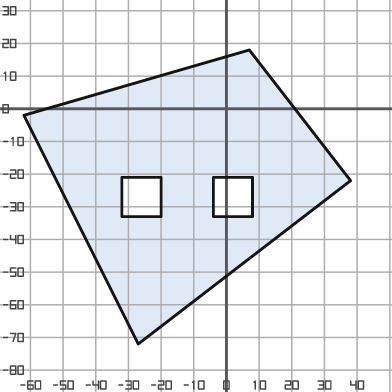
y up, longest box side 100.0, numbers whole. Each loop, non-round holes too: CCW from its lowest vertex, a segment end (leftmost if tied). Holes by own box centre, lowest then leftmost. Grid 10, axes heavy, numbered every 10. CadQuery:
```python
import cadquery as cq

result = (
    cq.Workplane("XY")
    .moveTo(-27.0, -72.0)
    .lineTo(38.0, -22.0)
    .lineTo(7.0, 18.0)
    .lineTo(-62.0, -2.0)
    .close()
    .moveTo(-32.0, -33.0)
    .lineTo(-20.0, -33.0)
    .lineTo(-20.0, -21.0)
    .lineTo(-32.0, -21.0)
    .close()
    .moveTo(-4.0, -33.0)
    .lineTo(8.0, -33.0)
    .lineTo(8.0, -21.0)
    .lineTo(-4.0, -21.0)
    .close()
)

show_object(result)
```